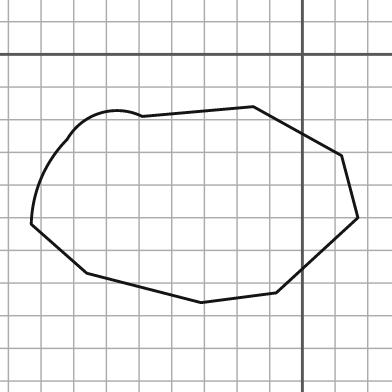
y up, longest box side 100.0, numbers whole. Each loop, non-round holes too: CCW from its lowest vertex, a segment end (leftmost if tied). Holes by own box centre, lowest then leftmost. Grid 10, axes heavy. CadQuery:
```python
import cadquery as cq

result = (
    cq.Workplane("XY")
    .moveTo(-31.0, -76.0)
    .lineTo(-8.0, -73.0)
    .lineTo(17.0, -50.0)
    .lineTo(12.0, -31.0)
    .lineTo(-15.0, -16.0)
    .lineTo(-49.0, -19.0)
    .threePointArc((-62.0, -18.0), (-72.0, -26.0))
    .threePointArc((-80.0, -38.0), (-83.0, -52.0))
    .lineTo(-66.0, -67.0)
    .close()
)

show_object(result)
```